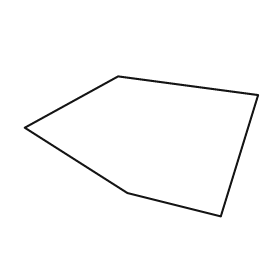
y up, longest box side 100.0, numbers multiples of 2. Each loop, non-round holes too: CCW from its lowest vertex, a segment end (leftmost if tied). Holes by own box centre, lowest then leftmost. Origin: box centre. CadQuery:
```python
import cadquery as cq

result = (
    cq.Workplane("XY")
    .moveTo(34.0, -30.0)
    .lineTo(50.0, 22.0)
    .lineTo(-10.0, 30.0)
    .lineTo(-50.0, 8.0)
    .lineTo(-6.0, -20.0)
    .close()
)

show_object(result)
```